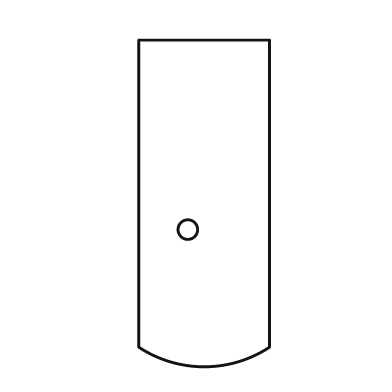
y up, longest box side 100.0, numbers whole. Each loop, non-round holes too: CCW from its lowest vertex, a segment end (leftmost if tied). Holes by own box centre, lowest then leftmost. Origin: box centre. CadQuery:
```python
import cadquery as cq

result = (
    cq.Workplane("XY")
    .moveTo(-20.0, -44.0)
    .threePointArc((0.0, -50.0), (20.0, -44.0))
    .lineTo(20.0, 50.0)
    .lineTo(-20.0, 50.0)
    .close()
    .moveTo(-5.0, -8.0)
    .circle(3.0)
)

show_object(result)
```